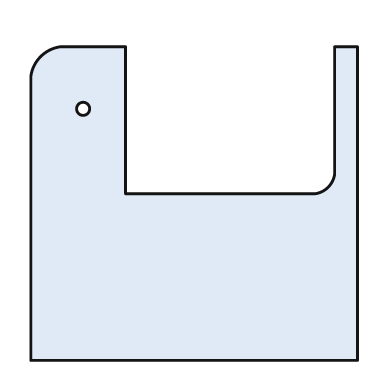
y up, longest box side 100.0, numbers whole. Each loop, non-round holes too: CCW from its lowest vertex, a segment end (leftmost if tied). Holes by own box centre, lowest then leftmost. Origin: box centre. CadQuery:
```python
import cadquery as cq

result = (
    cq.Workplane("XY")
    .moveTo(-50.0, -48.0)
    .lineTo(50.0, -48.0)
    .lineTo(50.0, 48.0)
    .lineTo(43.0, 48.0)
    .lineTo(43.0, 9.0)
    .threePointArc((41.0, 5.0), (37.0, 3.0))
    .lineTo(-21.0, 3.0)
    .lineTo(-21.0, 48.0)
    .lineTo(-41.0, 48.0)
    .threePointArc((-47.0, 45.0), (-50.0, 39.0))
    .close()
    .moveTo(-34.0, 29.0)
    .circle(2.0)
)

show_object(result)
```